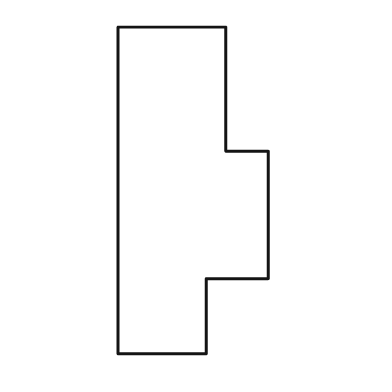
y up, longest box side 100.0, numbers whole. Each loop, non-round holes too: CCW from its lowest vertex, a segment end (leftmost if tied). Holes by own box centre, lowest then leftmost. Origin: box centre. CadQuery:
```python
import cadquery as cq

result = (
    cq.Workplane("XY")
    .moveTo(-23.0, -50.0)
    .lineTo(4.0, -50.0)
    .lineTo(4.0, -27.0)
    .lineTo(23.0, -27.0)
    .lineTo(23.0, 12.0)
    .lineTo(10.0, 12.0)
    .lineTo(10.0, 50.0)
    .lineTo(-23.0, 50.0)
    .close()
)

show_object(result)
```